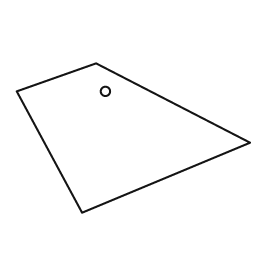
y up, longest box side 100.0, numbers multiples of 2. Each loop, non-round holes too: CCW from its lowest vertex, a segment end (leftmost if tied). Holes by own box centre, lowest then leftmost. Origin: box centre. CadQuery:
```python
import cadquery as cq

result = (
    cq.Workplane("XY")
    .moveTo(-22.0, -32.0)
    .lineTo(50.0, -2.0)
    .lineTo(-16.0, 32.0)
    .lineTo(-50.0, 20.0)
    .close()
    .moveTo(-12.0, 20.0)
    .circle(2.0)
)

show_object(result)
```